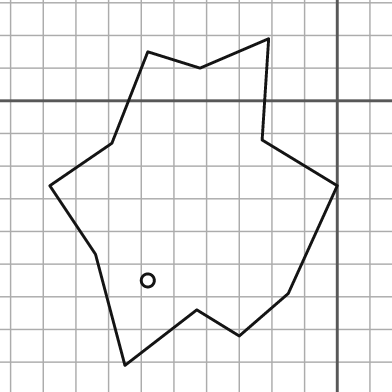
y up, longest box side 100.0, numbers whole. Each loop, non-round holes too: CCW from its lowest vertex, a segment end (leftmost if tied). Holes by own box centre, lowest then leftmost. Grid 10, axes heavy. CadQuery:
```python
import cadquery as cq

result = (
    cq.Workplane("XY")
    .moveTo(-65.0, -81.0)
    .lineTo(-43.0, -64.0)
    .lineTo(-30.0, -72.0)
    .lineTo(-15.0, -59.0)
    .lineTo(0.0, -26.0)
    .lineTo(-23.0, -12.0)
    .lineTo(-21.0, 19.0)
    .lineTo(-42.0, 10.0)
    .lineTo(-58.0, 15.0)
    .lineTo(-69.0, -13.0)
    .lineTo(-88.0, -26.0)
    .lineTo(-74.0, -47.0)
    .close()
    .moveTo(-58.0, -55.0)
    .circle(2.0)
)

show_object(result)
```